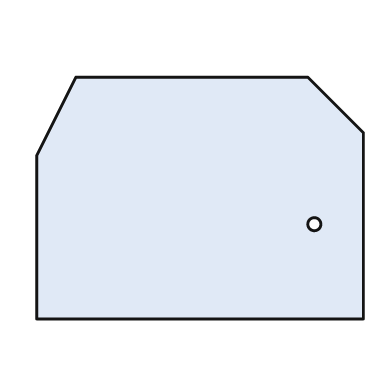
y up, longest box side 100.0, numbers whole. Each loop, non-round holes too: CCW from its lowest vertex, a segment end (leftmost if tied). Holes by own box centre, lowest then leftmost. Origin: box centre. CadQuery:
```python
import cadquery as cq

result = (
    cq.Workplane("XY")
    .moveTo(-50.0, -37.0)
    .lineTo(50.0, -37.0)
    .lineTo(50.0, 20.0)
    .lineTo(33.0, 37.0)
    .lineTo(-38.0, 37.0)
    .lineTo(-50.0, 13.0)
    .close()
    .moveTo(35.0, -8.0)
    .circle(2.0)
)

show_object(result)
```